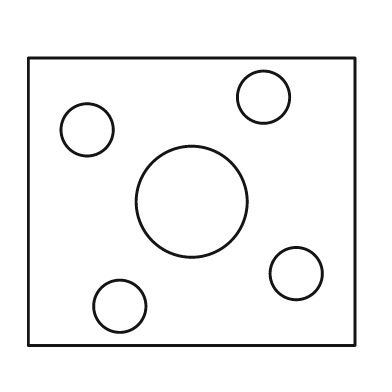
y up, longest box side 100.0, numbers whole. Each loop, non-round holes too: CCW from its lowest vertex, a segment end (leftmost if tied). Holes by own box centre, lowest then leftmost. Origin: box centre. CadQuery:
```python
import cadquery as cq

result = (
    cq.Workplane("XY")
    .moveTo(-50.0, -44.0)
    .lineTo(50.0, -44.0)
    .lineTo(50.0, 44.0)
    .lineTo(-50.0, 44.0)
    .close()
    .moveTo(-22.0, -32.0)
    .circle(8.0)
    .moveTo(32.0, -22.0)
    .circle(8.0)
    .moveTo(0.0, 0.0)
    .circle(17.0)
    .moveTo(-32.0, 22.0)
    .circle(8.0)
    .moveTo(22.0, 32.0)
    .circle(8.0)
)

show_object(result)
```